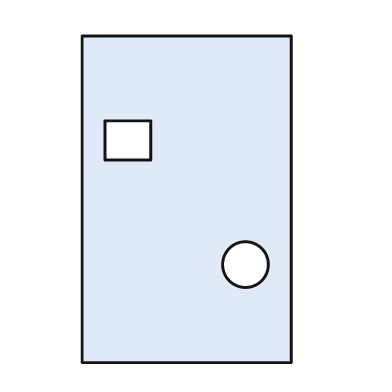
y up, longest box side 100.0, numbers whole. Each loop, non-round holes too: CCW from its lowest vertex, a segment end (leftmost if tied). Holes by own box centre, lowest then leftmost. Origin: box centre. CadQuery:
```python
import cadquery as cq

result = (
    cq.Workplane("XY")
    .moveTo(-32.0, -50.0)
    .lineTo(32.0, -50.0)
    .lineTo(32.0, 50.0)
    .lineTo(-32.0, 50.0)
    .close()
    .moveTo(18.0, -20.0)
    .circle(7.0)
    .moveTo(-25.0, 12.0)
    .lineTo(-11.0, 12.0)
    .lineTo(-11.0, 24.0)
    .lineTo(-25.0, 24.0)
    .close()
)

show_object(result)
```